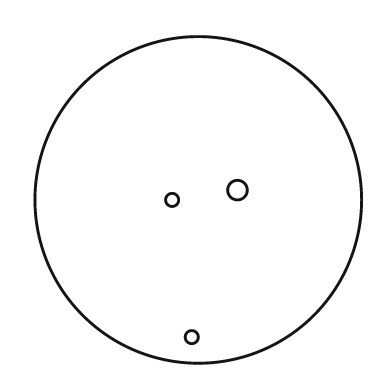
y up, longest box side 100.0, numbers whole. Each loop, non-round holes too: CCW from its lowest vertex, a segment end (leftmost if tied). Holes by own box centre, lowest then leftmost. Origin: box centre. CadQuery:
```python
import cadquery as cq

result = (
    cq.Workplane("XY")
    .moveTo(0.0, 0.0)
    .circle(50.0)
    .moveTo(-2.0, -42.0)
    .circle(2.0)
    .moveTo(-8.0, 0.0)
    .circle(2.0)
    .moveTo(12.0, 3.0)
    .circle(3.0)
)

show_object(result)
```